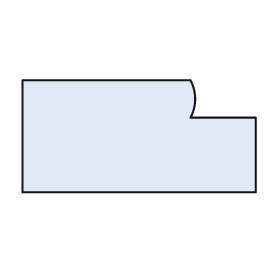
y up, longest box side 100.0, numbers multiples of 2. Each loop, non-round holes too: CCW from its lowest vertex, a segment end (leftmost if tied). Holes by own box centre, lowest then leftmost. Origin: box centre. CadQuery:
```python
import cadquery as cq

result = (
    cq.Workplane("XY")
    .moveTo(-50.0, -24.0)
    .lineTo(50.0, -24.0)
    .lineTo(50.0, 8.0)
    .lineTo(22.0, 8.0)
    .threePointArc((24.0, 16.0), (22.0, 24.0))
    .lineTo(-50.0, 24.0)
    .close()
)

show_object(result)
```